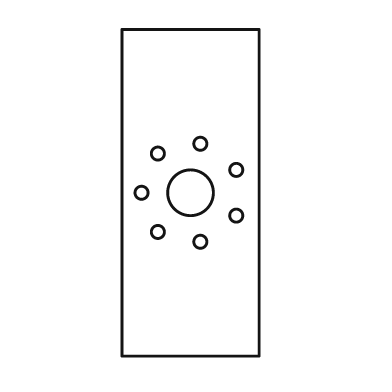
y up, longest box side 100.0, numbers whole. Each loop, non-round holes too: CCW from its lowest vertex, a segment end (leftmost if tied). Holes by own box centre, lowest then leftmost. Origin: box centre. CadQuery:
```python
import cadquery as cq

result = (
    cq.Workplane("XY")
    .moveTo(-21.0, -50.0)
    .lineTo(21.0, -50.0)
    .lineTo(21.0, 50.0)
    .lineTo(-21.0, 50.0)
    .close()
    .moveTo(3.0, -15.0)
    .circle(2.0)
    .moveTo(-10.0, -12.0)
    .circle(2.0)
    .moveTo(14.0, -7.0)
    .circle(2.0)
    .moveTo(-15.0, 0.0)
    .circle(2.0)
    .moveTo(0.0, 0.0)
    .circle(7.0)
    .moveTo(14.0, 7.0)
    .circle(2.0)
    .moveTo(-10.0, 12.0)
    .circle(2.0)
    .moveTo(3.0, 15.0)
    .circle(2.0)
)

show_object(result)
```